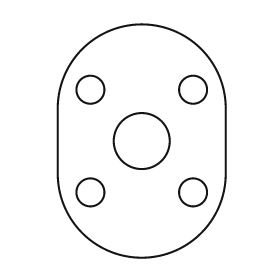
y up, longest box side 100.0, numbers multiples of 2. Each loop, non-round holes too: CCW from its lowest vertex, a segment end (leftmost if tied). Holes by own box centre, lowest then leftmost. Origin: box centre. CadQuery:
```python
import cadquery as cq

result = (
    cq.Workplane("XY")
    .moveTo(-36.0, -14.0)
    .threePointArc((0.0, -50.0), (36.0, -14.0))
    .lineTo(36.0, 14.0)
    .threePointArc((0.0, 50.0), (-36.0, 14.0))
    .close()
    .moveTo(-22.0, -22.0)
    .circle(6.0)
    .moveTo(22.0, -22.0)
    .circle(6.0)
    .moveTo(0.0, 0.0)
    .circle(12.0)
    .moveTo(-22.0, 22.0)
    .circle(6.0)
    .moveTo(22.0, 22.0)
    .circle(6.0)
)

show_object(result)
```